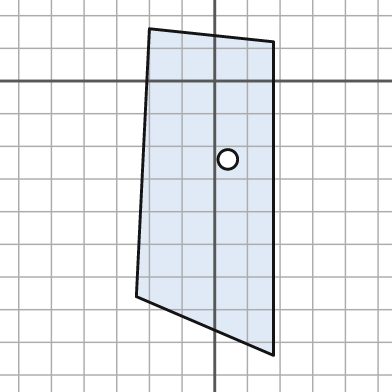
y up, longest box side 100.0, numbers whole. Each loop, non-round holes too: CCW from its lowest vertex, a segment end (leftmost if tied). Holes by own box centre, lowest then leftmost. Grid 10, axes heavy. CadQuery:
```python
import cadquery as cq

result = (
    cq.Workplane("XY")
    .moveTo(18.0, -84.0)
    .lineTo(18.0, 12.0)
    .lineTo(-20.0, 16.0)
    .lineTo(-24.0, -66.0)
    .close()
    .moveTo(4.0, -24.0)
    .circle(3.0)
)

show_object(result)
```